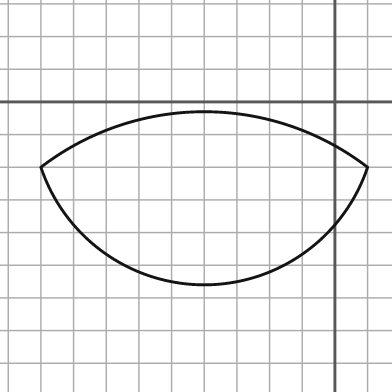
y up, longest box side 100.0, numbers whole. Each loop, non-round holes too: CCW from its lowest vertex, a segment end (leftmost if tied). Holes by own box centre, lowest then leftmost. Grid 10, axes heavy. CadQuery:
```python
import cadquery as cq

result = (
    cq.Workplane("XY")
    .moveTo(-90.0, -20.0)
    .threePointArc((-40.0, -56.0), (10.0, -20.0))
    .threePointArc((-40.0, -3.0), (-90.0, -20.0))
    .close()
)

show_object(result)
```